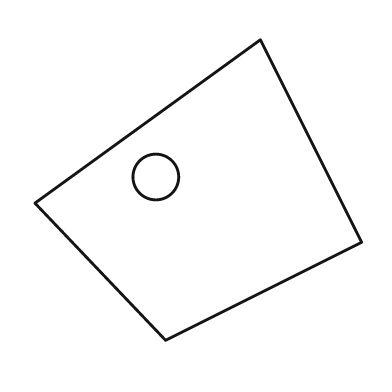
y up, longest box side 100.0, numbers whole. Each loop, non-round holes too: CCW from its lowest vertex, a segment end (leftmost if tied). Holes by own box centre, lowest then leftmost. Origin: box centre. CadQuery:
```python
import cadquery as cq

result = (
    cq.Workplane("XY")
    .moveTo(-10.0, -46.0)
    .lineTo(50.0, -16.0)
    .lineTo(19.0, 46.0)
    .lineTo(-50.0, -4.0)
    .close()
    .moveTo(-13.0, 4.0)
    .circle(7.0)
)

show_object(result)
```